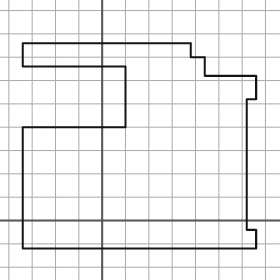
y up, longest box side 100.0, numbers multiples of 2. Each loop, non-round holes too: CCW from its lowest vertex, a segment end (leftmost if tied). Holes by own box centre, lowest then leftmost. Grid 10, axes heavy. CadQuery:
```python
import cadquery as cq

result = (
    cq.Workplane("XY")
    .moveTo(-34.0, -12.0)
    .lineTo(66.0, -12.0)
    .lineTo(66.0, -4.0)
    .lineTo(62.0, -4.0)
    .lineTo(62.0, 52.0)
    .lineTo(66.0, 52.0)
    .lineTo(66.0, 62.0)
    .lineTo(44.0, 62.0)
    .lineTo(44.0, 70.0)
    .lineTo(38.0, 70.0)
    .lineTo(38.0, 76.0)
    .lineTo(-34.0, 76.0)
    .lineTo(-34.0, 66.0)
    .lineTo(10.0, 66.0)
    .lineTo(10.0, 40.0)
    .lineTo(-34.0, 40.0)
    .close()
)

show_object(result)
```